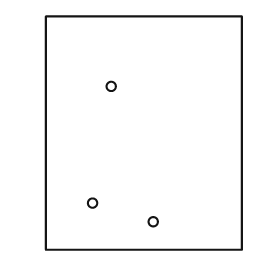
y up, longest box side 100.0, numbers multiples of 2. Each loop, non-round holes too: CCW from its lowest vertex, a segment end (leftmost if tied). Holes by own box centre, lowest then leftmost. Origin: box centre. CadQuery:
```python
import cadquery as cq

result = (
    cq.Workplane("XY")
    .moveTo(-42.0, -50.0)
    .lineTo(42.0, -50.0)
    .lineTo(42.0, 50.0)
    .lineTo(-42.0, 50.0)
    .close()
    .moveTo(4.0, -38.0)
    .circle(2.0)
    .moveTo(-22.0, -30.0)
    .circle(2.0)
    .moveTo(-14.0, 20.0)
    .circle(2.0)
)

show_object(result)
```